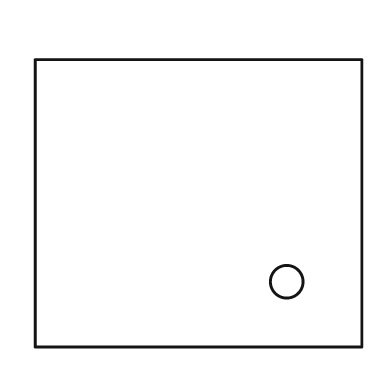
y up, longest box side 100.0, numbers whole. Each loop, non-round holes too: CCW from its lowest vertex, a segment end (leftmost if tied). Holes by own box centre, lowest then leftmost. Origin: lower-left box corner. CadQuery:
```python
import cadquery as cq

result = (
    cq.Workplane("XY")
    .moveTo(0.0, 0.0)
    .lineTo(100.0, 0.0)
    .lineTo(100.0, 88.0)
    .lineTo(0.0, 88.0)
    .close()
    .moveTo(77.0, 20.0)
    .circle(5.0)
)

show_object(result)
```